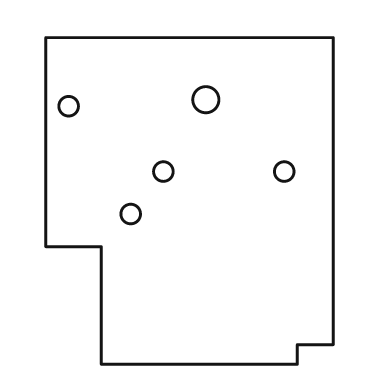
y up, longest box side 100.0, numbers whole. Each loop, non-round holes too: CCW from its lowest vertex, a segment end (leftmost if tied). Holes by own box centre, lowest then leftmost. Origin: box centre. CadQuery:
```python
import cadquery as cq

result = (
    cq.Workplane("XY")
    .moveTo(-27.0, -50.0)
    .lineTo(33.0, -50.0)
    .lineTo(33.0, -44.0)
    .lineTo(44.0, -44.0)
    .lineTo(44.0, 50.0)
    .lineTo(-44.0, 50.0)
    .lineTo(-44.0, -14.0)
    .lineTo(-27.0, -14.0)
    .close()
    .moveTo(-18.0, -4.0)
    .circle(3.0)
    .moveTo(-8.0, 9.0)
    .circle(3.0)
    .moveTo(29.0, 9.0)
    .circle(3.0)
    .moveTo(-37.0, 29.0)
    .circle(3.0)
    .moveTo(5.0, 31.0)
    .circle(4.0)
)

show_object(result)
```